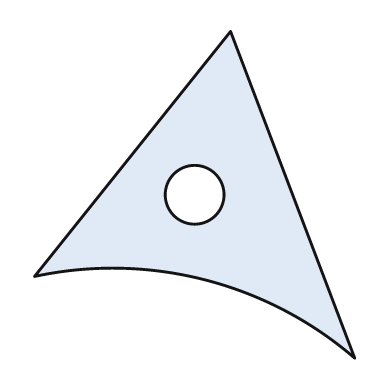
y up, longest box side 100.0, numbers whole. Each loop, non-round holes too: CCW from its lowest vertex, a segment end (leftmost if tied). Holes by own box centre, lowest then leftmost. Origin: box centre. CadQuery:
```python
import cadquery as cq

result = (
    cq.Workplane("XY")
    .moveTo(49.0, -50.0)
    .lineTo(11.0, 50.0)
    .lineTo(-49.0, -25.0)
    .threePointArc((3.0, -26.0), (49.0, -50.0))
    .close()
    .moveTo(0.0, 0.0)
    .circle(9.0)
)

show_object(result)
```